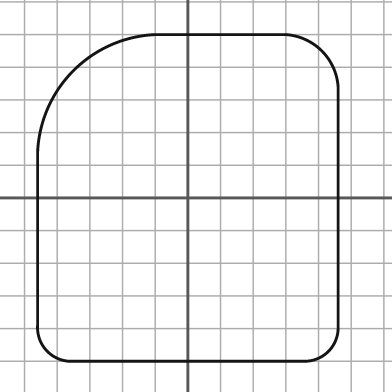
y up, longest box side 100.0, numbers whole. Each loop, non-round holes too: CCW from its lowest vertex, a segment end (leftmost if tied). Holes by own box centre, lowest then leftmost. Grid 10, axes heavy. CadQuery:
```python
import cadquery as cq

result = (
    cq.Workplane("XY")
    .moveTo(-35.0, -50.0)
    .lineTo(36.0, -50.0)
    .threePointArc((43.0, -47.0), (46.0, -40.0))
    .lineTo(46.0, 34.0)
    .threePointArc((41.0, 45.0), (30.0, 50.0))
    .lineTo(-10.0, 50.0)
    .threePointArc((-35.0, 39.0), (-46.0, 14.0))
    .lineTo(-46.0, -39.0)
    .threePointArc((-43.0, -47.0), (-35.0, -50.0))
    .close()
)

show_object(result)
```